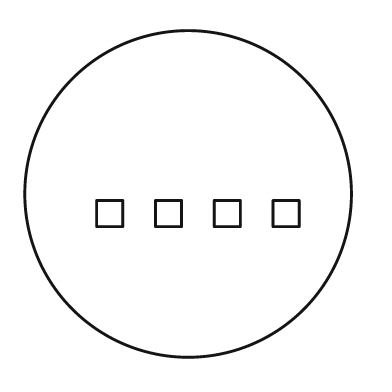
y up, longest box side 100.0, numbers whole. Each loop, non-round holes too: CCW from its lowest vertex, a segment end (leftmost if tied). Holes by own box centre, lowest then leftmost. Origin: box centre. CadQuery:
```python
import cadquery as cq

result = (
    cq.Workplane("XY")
    .moveTo(0.0, 0.0)
    .circle(50.0)
    .moveTo(-28.0, -10.0)
    .lineTo(-20.0, -10.0)
    .lineTo(-20.0, -2.0)
    .lineTo(-28.0, -2.0)
    .close()
    .moveTo(-10.0, -10.0)
    .lineTo(-2.0, -10.0)
    .lineTo(-2.0, -2.0)
    .lineTo(-10.0, -2.0)
    .close()
    .moveTo(8.0, -10.0)
    .lineTo(16.0, -10.0)
    .lineTo(16.0, -2.0)
    .lineTo(8.0, -2.0)
    .close()
    .moveTo(26.0, -10.0)
    .lineTo(34.0, -10.0)
    .lineTo(34.0, -2.0)
    .lineTo(26.0, -2.0)
    .close()
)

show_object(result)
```